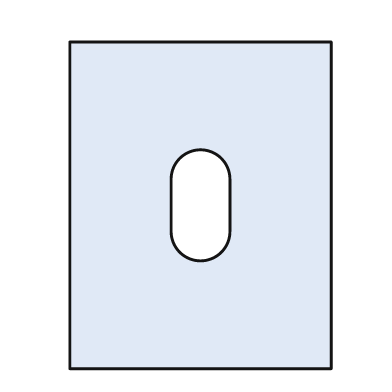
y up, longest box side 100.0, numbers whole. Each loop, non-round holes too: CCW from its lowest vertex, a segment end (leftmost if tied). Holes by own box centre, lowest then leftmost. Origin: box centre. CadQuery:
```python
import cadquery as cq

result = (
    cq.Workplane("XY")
    .moveTo(-40.0, -50.0)
    .lineTo(40.0, -50.0)
    .lineTo(40.0, 50.0)
    .lineTo(-40.0, 50.0)
    .close()
    .moveTo(-9.0, -8.0)
    .threePointArc((0.0, -17.0), (9.0, -8.0))
    .lineTo(9.0, 8.0)
    .threePointArc((0.0, 17.0), (-9.0, 8.0))
    .close()
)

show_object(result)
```